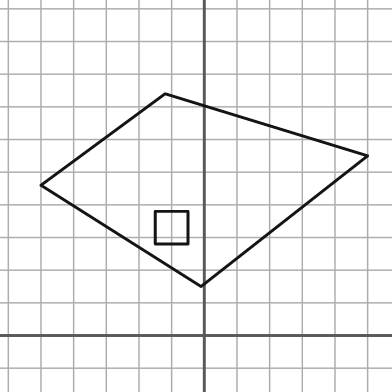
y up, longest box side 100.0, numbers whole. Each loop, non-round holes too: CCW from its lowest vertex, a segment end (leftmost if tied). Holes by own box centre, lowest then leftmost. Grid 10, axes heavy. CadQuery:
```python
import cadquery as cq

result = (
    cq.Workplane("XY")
    .moveTo(-1.0, 15.0)
    .lineTo(50.0, 55.0)
    .lineTo(-12.0, 74.0)
    .lineTo(-50.0, 46.0)
    .close()
    .moveTo(-15.0, 28.0)
    .lineTo(-5.0, 28.0)
    .lineTo(-5.0, 38.0)
    .lineTo(-15.0, 38.0)
    .close()
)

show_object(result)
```